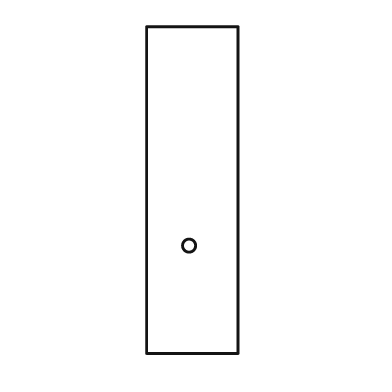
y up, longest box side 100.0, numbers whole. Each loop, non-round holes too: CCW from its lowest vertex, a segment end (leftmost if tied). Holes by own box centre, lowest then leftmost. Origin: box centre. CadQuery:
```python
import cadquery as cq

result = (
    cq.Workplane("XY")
    .moveTo(-14.0, -50.0)
    .lineTo(14.0, -50.0)
    .lineTo(14.0, 50.0)
    .lineTo(-14.0, 50.0)
    .close()
    .moveTo(-1.0, -17.0)
    .circle(2.0)
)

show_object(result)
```